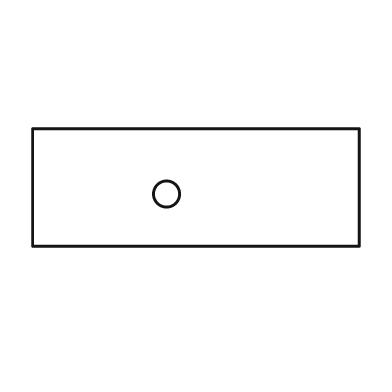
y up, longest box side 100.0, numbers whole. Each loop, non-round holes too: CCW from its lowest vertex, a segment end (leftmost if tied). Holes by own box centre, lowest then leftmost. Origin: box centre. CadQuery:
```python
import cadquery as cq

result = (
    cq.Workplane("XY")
    .moveTo(-50.0, -18.0)
    .lineTo(50.0, -18.0)
    .lineTo(50.0, 18.0)
    .lineTo(-50.0, 18.0)
    .close()
    .moveTo(-9.0, -2.0)
    .circle(4.0)
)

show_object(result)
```